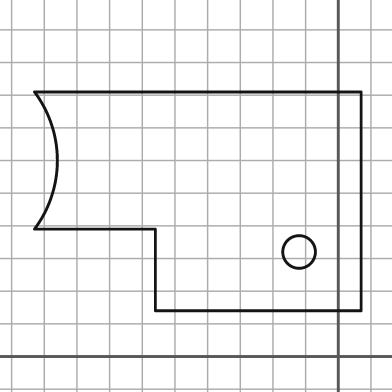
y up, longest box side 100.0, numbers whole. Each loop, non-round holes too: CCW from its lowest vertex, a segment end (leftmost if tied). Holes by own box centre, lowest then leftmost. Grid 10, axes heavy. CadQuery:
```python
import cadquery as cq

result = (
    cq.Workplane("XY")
    .moveTo(-56.0, 14.0)
    .lineTo(7.0, 14.0)
    .lineTo(7.0, 81.0)
    .lineTo(-93.0, 81.0)
    .threePointArc((-86.0, 60.0), (-93.0, 39.0))
    .lineTo(-56.0, 39.0)
    .close()
    .moveTo(-12.0, 32.0)
    .circle(5.0)
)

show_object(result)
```